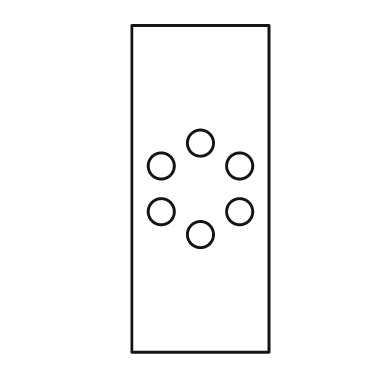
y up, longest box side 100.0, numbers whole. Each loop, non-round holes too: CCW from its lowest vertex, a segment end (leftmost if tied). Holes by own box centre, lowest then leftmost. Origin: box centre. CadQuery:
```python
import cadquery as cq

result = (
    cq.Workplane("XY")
    .moveTo(-21.0, -50.0)
    .lineTo(21.0, -50.0)
    .lineTo(21.0, 50.0)
    .lineTo(-21.0, 50.0)
    .close()
    .moveTo(0.0, -14.0)
    .circle(4.0)
    .moveTo(-12.0, -7.0)
    .circle(4.0)
    .moveTo(12.0, -7.0)
    .circle(4.0)
    .moveTo(-12.0, 7.0)
    .circle(4.0)
    .moveTo(12.0, 7.0)
    .circle(4.0)
    .moveTo(0.0, 14.0)
    .circle(4.0)
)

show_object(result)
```